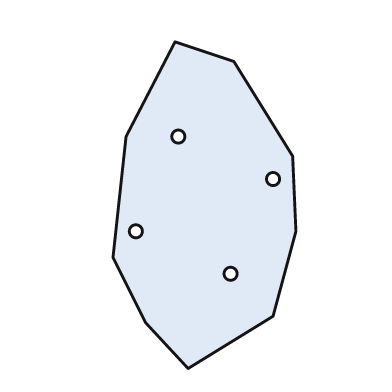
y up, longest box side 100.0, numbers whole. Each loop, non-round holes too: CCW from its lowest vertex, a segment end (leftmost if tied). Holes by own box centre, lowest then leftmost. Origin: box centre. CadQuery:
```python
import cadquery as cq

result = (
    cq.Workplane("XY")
    .moveTo(-5.0, -50.0)
    .lineTo(21.0, -34.0)
    .lineTo(28.0, -8.0)
    .lineTo(27.0, 15.0)
    .lineTo(9.0, 44.0)
    .lineTo(-9.0, 50.0)
    .lineTo(-24.0, 21.0)
    .lineTo(-28.0, -16.0)
    .lineTo(-18.0, -36.0)
    .close()
    .moveTo(8.0, -21.0)
    .circle(2.0)
    .moveTo(-21.0, -8.0)
    .circle(2.0)
    .moveTo(21.0, 8.0)
    .circle(2.0)
    .moveTo(-8.0, 21.0)
    .circle(2.0)
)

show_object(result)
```